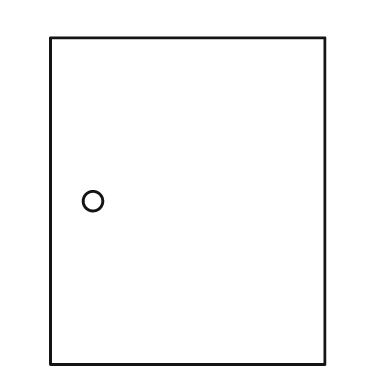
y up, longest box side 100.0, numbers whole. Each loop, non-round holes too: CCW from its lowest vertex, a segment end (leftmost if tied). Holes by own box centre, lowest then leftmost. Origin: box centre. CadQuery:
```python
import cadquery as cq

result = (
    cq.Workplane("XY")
    .moveTo(-42.0, -50.0)
    .lineTo(42.0, -50.0)
    .lineTo(42.0, 50.0)
    .lineTo(-42.0, 50.0)
    .close()
    .moveTo(-29.0, 0.0)
    .circle(3.0)
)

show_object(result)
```